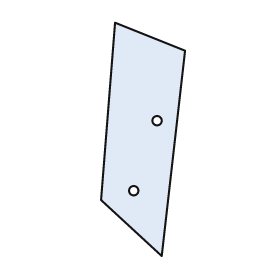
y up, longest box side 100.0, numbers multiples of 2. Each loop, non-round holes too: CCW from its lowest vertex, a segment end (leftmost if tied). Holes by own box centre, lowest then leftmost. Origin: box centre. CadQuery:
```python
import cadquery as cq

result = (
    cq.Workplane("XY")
    .moveTo(8.0, -50.0)
    .lineTo(18.0, 38.0)
    .lineTo(-12.0, 50.0)
    .lineTo(-18.0, -26.0)
    .close()
    .moveTo(-4.0, -22.0)
    .circle(2.0)
    .moveTo(6.0, 8.0)
    .circle(2.0)
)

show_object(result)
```